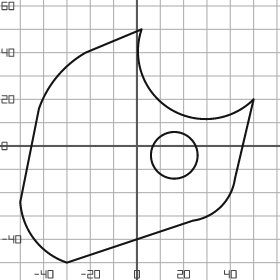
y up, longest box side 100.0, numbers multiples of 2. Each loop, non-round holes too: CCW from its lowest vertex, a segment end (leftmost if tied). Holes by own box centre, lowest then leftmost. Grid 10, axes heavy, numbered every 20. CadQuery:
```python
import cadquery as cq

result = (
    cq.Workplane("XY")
    .moveTo(-30.0, -50.0)
    .lineTo(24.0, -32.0)
    .threePointArc((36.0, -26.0), (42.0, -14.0))
    .lineTo(50.0, 20.0)
    .threePointArc((14.0, 16.0), (2.0, 50.0))
    .lineTo(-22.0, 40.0)
    .threePointArc((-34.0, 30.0), (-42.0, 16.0))
    .lineTo(-50.0, -24.0)
    .threePointArc((-44.0, -40.0), (-30.0, -50.0))
    .close()
    .moveTo(16.0, -4.0)
    .circle(10.0)
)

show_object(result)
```